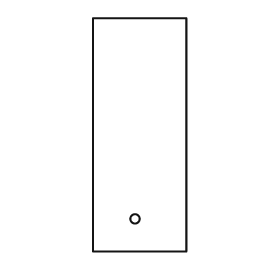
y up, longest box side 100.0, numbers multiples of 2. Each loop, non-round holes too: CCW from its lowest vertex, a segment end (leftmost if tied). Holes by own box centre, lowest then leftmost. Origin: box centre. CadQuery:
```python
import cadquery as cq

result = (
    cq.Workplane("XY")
    .moveTo(-20.0, -50.0)
    .lineTo(20.0, -50.0)
    .lineTo(20.0, 50.0)
    .lineTo(-20.0, 50.0)
    .close()
    .moveTo(-2.0, -36.0)
    .circle(2.0)
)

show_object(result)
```